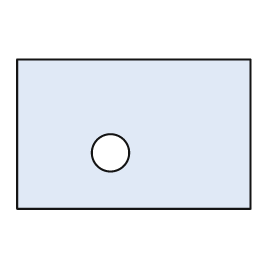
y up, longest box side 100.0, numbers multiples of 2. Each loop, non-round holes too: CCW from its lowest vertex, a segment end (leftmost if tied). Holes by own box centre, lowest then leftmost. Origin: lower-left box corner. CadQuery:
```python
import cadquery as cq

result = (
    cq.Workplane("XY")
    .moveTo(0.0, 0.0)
    .lineTo(100.0, 0.0)
    .lineTo(100.0, 64.0)
    .lineTo(0.0, 64.0)
    .close()
    .moveTo(40.0, 24.0)
    .circle(8.0)
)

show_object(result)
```